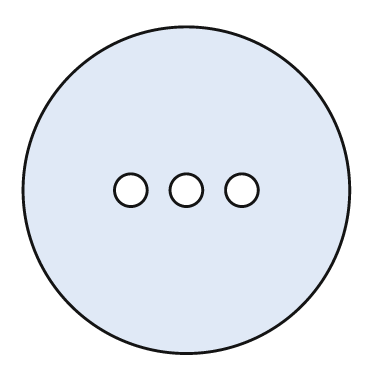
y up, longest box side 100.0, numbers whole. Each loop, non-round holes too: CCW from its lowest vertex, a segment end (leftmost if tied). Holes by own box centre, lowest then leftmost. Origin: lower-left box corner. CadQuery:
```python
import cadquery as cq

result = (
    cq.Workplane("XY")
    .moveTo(50.0, 50.0)
    .circle(50.0)
    .moveTo(33.0, 50.0)
    .circle(5.0)
    .moveTo(50.0, 50.0)
    .circle(5.0)
    .moveTo(67.0, 50.0)
    .circle(5.0)
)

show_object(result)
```